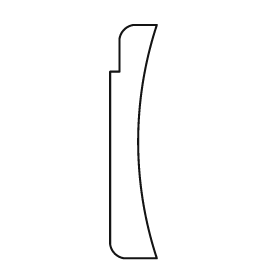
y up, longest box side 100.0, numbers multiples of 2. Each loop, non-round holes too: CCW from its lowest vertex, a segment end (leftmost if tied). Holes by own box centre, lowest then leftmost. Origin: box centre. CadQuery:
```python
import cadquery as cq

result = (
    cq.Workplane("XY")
    .moveTo(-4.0, -50.0)
    .lineTo(10.0, -50.0)
    .threePointArc((2.0, 0.0), (10.0, 50.0))
    .lineTo(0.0, 50.0)
    .threePointArc((-4.0, 48.0), (-6.0, 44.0))
    .lineTo(-6.0, 30.0)
    .lineTo(-10.0, 30.0)
    .lineTo(-10.0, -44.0)
    .threePointArc((-8.0, -48.0), (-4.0, -50.0))
    .close()
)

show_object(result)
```